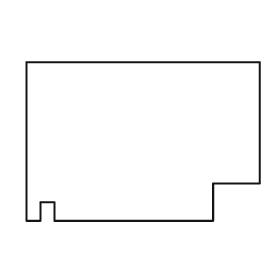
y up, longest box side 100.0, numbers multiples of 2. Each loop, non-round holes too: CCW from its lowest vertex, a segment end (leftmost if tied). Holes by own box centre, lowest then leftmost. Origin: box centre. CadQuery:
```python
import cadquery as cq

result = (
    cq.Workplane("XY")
    .moveTo(-50.0, -34.0)
    .lineTo(-44.0, -34.0)
    .lineTo(-44.0, -26.0)
    .lineTo(-38.0, -26.0)
    .lineTo(-38.0, -34.0)
    .lineTo(30.0, -34.0)
    .lineTo(30.0, -18.0)
    .lineTo(50.0, -18.0)
    .lineTo(50.0, 34.0)
    .lineTo(-50.0, 34.0)
    .close()
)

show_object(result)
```